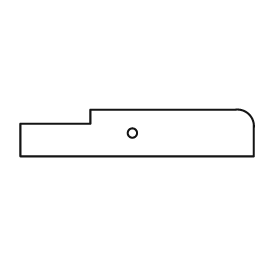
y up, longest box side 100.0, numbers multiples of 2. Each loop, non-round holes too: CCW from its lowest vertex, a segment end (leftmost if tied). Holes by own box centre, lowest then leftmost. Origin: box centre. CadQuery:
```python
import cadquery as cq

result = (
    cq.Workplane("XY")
    .moveTo(-50.0, -10.0)
    .lineTo(50.0, -10.0)
    .lineTo(50.0, 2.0)
    .threePointArc((48.0, 8.0), (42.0, 10.0))
    .lineTo(-20.0, 10.0)
    .lineTo(-20.0, 4.0)
    .lineTo(-50.0, 4.0)
    .close()
    .moveTo(-2.0, 0.0)
    .circle(2.0)
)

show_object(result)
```